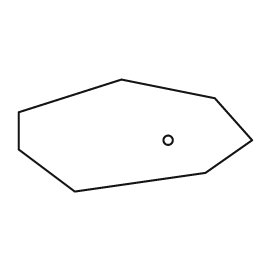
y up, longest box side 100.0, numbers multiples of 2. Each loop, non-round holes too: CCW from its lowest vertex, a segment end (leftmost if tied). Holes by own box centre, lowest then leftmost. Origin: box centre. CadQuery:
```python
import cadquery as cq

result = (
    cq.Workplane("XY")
    .moveTo(-26.0, -24.0)
    .lineTo(30.0, -16.0)
    .lineTo(50.0, -2.0)
    .lineTo(34.0, 16.0)
    .lineTo(-6.0, 24.0)
    .lineTo(-50.0, 10.0)
    .lineTo(-50.0, -6.0)
    .close()
    .moveTo(14.0, -2.0)
    .circle(2.0)
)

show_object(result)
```